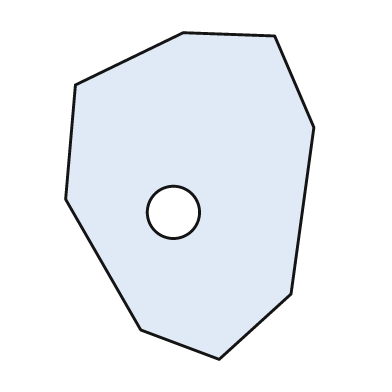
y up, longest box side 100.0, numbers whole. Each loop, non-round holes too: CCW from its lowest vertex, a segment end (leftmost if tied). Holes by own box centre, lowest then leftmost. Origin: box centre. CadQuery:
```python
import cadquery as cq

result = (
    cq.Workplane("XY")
    .moveTo(9.0, -50.0)
    .lineTo(31.0, -30.0)
    .lineTo(38.0, 21.0)
    .lineTo(26.0, 49.0)
    .lineTo(-2.0, 50.0)
    .lineTo(-35.0, 34.0)
    .lineTo(-38.0, -1.0)
    .lineTo(-15.0, -41.0)
    .close()
    .moveTo(-5.0, -5.0)
    .circle(8.0)
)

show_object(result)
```